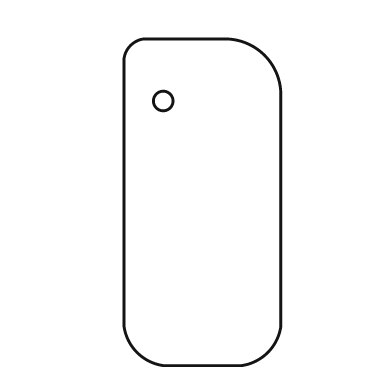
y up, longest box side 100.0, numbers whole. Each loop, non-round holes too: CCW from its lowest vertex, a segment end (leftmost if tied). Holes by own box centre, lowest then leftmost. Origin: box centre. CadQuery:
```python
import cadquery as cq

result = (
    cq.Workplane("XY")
    .moveTo(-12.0, -50.0)
    .lineTo(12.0, -50.0)
    .threePointArc((20.0, -46.0), (24.0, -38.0))
    .lineTo(24.0, 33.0)
    .threePointArc((19.0, 45.0), (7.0, 50.0))
    .lineTo(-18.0, 50.0)
    .threePointArc((-22.0, 48.0), (-24.0, 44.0))
    .lineTo(-24.0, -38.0)
    .threePointArc((-20.0, -46.0), (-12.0, -50.0))
    .close()
    .moveTo(-12.0, 31.0)
    .circle(3.0)
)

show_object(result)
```